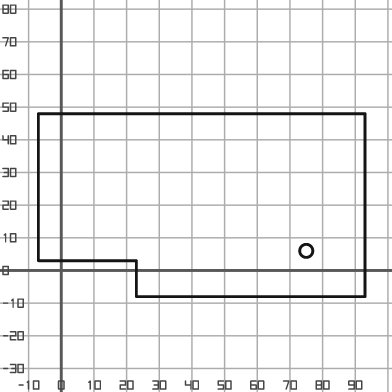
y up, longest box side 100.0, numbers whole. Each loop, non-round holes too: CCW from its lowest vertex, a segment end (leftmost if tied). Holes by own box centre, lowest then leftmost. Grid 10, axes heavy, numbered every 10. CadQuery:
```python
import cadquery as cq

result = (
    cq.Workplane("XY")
    .moveTo(23.0, -8.0)
    .lineTo(93.0, -8.0)
    .lineTo(93.0, 48.0)
    .lineTo(-7.0, 48.0)
    .lineTo(-7.0, 3.0)
    .lineTo(23.0, 3.0)
    .close()
    .moveTo(75.0, 6.0)
    .circle(2.0)
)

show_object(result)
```